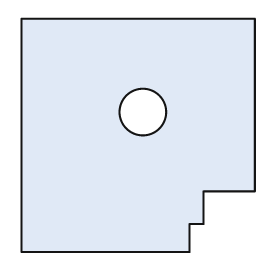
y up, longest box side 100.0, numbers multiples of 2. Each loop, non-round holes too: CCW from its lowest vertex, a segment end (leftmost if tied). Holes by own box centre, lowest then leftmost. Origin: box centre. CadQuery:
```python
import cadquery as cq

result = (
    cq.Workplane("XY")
    .moveTo(-50.0, -50.0)
    .lineTo(22.0, -50.0)
    .lineTo(22.0, -38.0)
    .lineTo(28.0, -38.0)
    .lineTo(28.0, -24.0)
    .lineTo(50.0, -24.0)
    .lineTo(50.0, 50.0)
    .lineTo(-50.0, 50.0)
    .close()
    .moveTo(2.0, 10.0)
    .circle(10.0)
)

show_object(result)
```